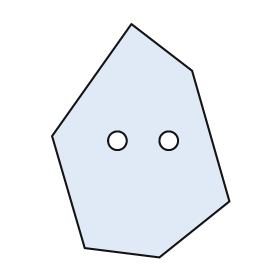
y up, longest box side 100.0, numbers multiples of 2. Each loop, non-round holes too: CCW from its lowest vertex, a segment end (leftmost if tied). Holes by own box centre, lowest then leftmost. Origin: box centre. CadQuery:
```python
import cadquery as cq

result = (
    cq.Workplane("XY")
    .moveTo(8.0, -50.0)
    .lineTo(38.0, -26.0)
    .lineTo(22.0, 30.0)
    .lineTo(-4.0, 50.0)
    .lineTo(-38.0, 2.0)
    .lineTo(-24.0, -46.0)
    .close()
    .moveTo(-10.0, 0.0)
    .circle(4.0)
    .moveTo(12.0, 0.0)
    .circle(4.0)
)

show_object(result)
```